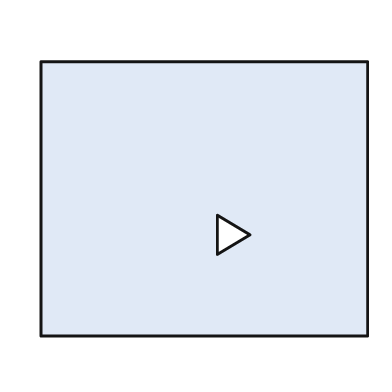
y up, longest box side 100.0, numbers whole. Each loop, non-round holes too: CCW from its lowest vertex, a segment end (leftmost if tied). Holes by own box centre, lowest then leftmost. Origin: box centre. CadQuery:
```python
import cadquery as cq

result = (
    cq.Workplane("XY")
    .moveTo(-50.0, -42.0)
    .lineTo(50.0, -42.0)
    .lineTo(50.0, 42.0)
    .lineTo(-50.0, 42.0)
    .close()
    .moveTo(4.0, -17.0)
    .lineTo(14.0, -11.0)
    .lineTo(4.0, -5.0)
    .close()
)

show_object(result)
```